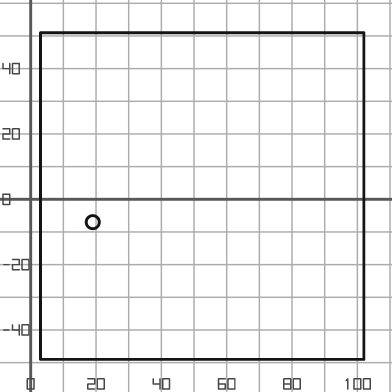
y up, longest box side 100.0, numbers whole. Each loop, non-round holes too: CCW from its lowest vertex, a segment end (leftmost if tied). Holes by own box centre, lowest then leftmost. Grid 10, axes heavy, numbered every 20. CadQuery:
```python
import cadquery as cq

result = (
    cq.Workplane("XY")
    .moveTo(3.0, -49.0)
    .lineTo(102.0, -49.0)
    .lineTo(102.0, 51.0)
    .lineTo(3.0, 51.0)
    .close()
    .moveTo(19.0, -7.0)
    .circle(2.0)
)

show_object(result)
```